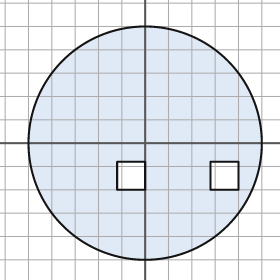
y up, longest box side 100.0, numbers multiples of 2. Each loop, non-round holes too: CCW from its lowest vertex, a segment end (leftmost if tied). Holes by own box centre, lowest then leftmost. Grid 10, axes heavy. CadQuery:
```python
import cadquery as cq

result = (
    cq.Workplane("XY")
    .moveTo(0.0, 0.0)
    .circle(50.0)
    .moveTo(-12.0, -20.0)
    .lineTo(0.0, -20.0)
    .lineTo(0.0, -8.0)
    .lineTo(-12.0, -8.0)
    .close()
    .moveTo(28.0, -20.0)
    .lineTo(40.0, -20.0)
    .lineTo(40.0, -8.0)
    .lineTo(28.0, -8.0)
    .close()
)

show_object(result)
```